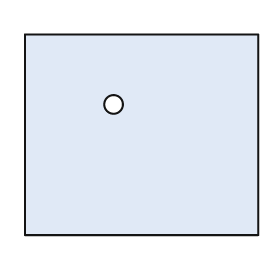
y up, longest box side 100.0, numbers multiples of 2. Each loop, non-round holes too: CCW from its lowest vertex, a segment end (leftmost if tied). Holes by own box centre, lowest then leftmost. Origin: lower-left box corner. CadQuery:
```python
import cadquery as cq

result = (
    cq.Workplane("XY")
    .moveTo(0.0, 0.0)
    .lineTo(100.0, 0.0)
    .lineTo(100.0, 86.0)
    .lineTo(0.0, 86.0)
    .close()
    .moveTo(38.0, 56.0)
    .circle(4.0)
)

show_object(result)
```